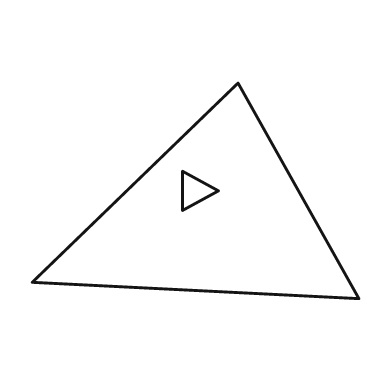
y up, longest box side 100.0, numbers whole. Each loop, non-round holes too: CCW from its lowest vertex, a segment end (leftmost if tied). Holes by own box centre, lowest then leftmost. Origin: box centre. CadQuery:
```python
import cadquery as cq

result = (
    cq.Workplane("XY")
    .moveTo(50.0, -33.0)
    .lineTo(13.0, 33.0)
    .lineTo(-50.0, -28.0)
    .close()
    .moveTo(-4.0, -6.0)
    .lineTo(7.0, 0.0)
    .lineTo(-4.0, 6.0)
    .close()
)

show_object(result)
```